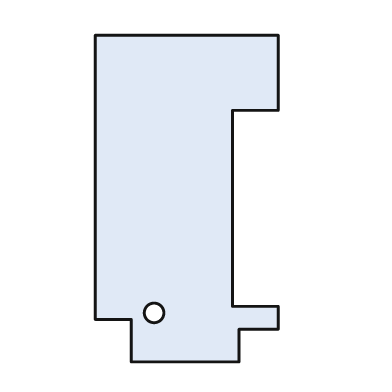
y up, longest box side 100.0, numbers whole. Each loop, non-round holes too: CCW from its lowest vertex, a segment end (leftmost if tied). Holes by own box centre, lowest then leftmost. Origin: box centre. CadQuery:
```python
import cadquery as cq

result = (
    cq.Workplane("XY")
    .moveTo(-17.0, -50.0)
    .lineTo(16.0, -50.0)
    .lineTo(16.0, -40.0)
    .lineTo(28.0, -40.0)
    .lineTo(28.0, -33.0)
    .lineTo(14.0, -33.0)
    .lineTo(14.0, 27.0)
    .lineTo(28.0, 27.0)
    .lineTo(28.0, 50.0)
    .lineTo(-28.0, 50.0)
    .lineTo(-28.0, -37.0)
    .lineTo(-17.0, -37.0)
    .close()
    .moveTo(-10.0, -35.0)
    .circle(3.0)
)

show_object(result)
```